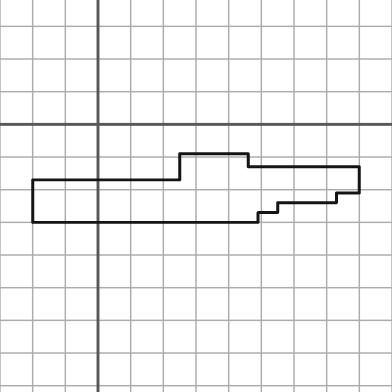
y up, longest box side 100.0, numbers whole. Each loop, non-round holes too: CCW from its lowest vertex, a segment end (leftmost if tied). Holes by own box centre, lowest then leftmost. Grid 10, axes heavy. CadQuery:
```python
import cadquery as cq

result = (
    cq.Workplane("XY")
    .moveTo(-20.0, -30.0)
    .lineTo(49.0, -30.0)
    .lineTo(49.0, -27.0)
    .lineTo(55.0, -27.0)
    .lineTo(55.0, -24.0)
    .lineTo(73.0, -24.0)
    .lineTo(73.0, -21.0)
    .lineTo(80.0, -21.0)
    .lineTo(80.0, -13.0)
    .lineTo(46.0, -13.0)
    .lineTo(46.0, -9.0)
    .lineTo(25.0, -9.0)
    .lineTo(25.0, -17.0)
    .lineTo(-20.0, -17.0)
    .close()
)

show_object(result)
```